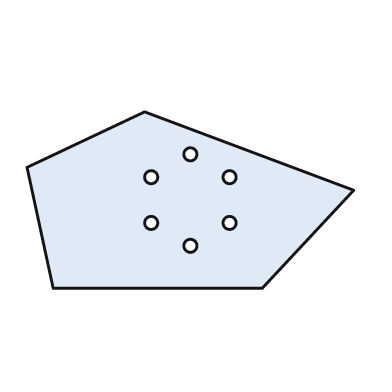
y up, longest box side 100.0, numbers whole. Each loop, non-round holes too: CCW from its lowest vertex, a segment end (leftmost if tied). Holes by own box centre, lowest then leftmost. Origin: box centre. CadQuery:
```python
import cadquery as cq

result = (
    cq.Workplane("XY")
    .moveTo(-42.0, -27.0)
    .lineTo(22.0, -27.0)
    .lineTo(50.0, 3.0)
    .lineTo(-14.0, 27.0)
    .lineTo(-50.0, 10.0)
    .close()
    .moveTo(0.0, -14.0)
    .circle(2.0)
    .moveTo(-12.0, -7.0)
    .circle(2.0)
    .moveTo(12.0, -7.0)
    .circle(2.0)
    .moveTo(-12.0, 7.0)
    .circle(2.0)
    .moveTo(12.0, 7.0)
    .circle(2.0)
    .moveTo(0.0, 14.0)
    .circle(2.0)
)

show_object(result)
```